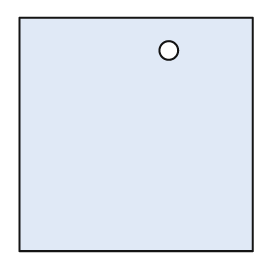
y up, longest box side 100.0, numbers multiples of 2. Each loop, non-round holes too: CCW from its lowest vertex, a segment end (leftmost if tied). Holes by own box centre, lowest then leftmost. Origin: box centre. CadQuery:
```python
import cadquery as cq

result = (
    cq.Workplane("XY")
    .moveTo(-50.0, -50.0)
    .lineTo(50.0, -50.0)
    .lineTo(50.0, 50.0)
    .lineTo(-50.0, 50.0)
    .close()
    .moveTo(14.0, 36.0)
    .circle(4.0)
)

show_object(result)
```